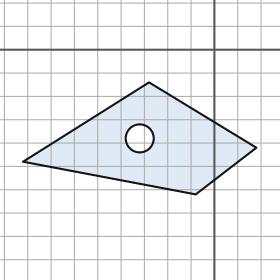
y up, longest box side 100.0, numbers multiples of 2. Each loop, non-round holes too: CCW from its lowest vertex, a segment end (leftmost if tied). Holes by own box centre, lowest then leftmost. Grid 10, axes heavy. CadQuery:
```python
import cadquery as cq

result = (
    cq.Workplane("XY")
    .moveTo(-8.0, -62.0)
    .lineTo(18.0, -42.0)
    .lineTo(-28.0, -14.0)
    .lineTo(-82.0, -48.0)
    .close()
    .moveTo(-32.0, -38.0)
    .circle(6.0)
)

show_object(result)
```